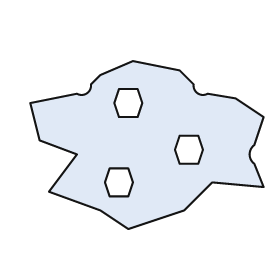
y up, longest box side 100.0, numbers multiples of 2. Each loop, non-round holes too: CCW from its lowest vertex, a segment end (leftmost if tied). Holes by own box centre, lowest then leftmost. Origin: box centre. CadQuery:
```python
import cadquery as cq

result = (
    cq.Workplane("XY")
    .moveTo(-8.0, -36.0)
    .lineTo(16.0, -28.0)
    .lineTo(28.0, -16.0)
    .lineTo(50.0, -18.0)
    .lineTo(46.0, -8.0)
    .threePointArc((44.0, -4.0), (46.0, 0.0))
    .lineTo(50.0, 12.0)
    .lineTo(38.0, 20.0)
    .lineTo(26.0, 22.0)
    .threePointArc((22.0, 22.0), (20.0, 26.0))
    .lineTo(14.0, 32.0)
    .lineTo(-6.0, 36.0)
    .lineTo(-20.0, 30.0)
    .lineTo(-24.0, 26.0)
    .threePointArc((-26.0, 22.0), (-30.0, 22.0))
    .lineTo(-50.0, 18.0)
    .lineTo(-46.0, 2.0)
    .lineTo(-30.0, -4.0)
    .lineTo(-42.0, -20.0)
    .lineTo(-20.0, -28.0)
    .close()
    .moveTo(-16.0, -22.0)
    .lineTo(-8.0, -22.0)
    .lineTo(-6.0, -16.0)
    .lineTo(-8.0, -10.0)
    .lineTo(-16.0, -10.0)
    .lineTo(-18.0, -16.0)
    .close()
    .moveTo(14.0, -8.0)
    .lineTo(22.0, -8.0)
    .lineTo(24.0, -2.0)
    .lineTo(22.0, 4.0)
    .lineTo(14.0, 4.0)
    .lineTo(12.0, -2.0)
    .close()
    .moveTo(-12.0, 12.0)
    .lineTo(-4.0, 12.0)
    .lineTo(-2.0, 18.0)
    .lineTo(-4.0, 24.0)
    .lineTo(-12.0, 24.0)
    .lineTo(-14.0, 18.0)
    .close()
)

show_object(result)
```